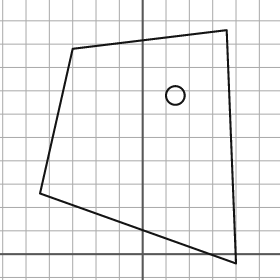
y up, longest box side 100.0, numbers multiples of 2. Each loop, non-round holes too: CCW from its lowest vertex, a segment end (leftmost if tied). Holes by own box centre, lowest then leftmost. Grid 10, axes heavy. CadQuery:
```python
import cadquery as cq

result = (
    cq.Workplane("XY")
    .moveTo(40.0, -4.0)
    .lineTo(36.0, 96.0)
    .lineTo(-30.0, 88.0)
    .lineTo(-44.0, 26.0)
    .close()
    .moveTo(14.0, 68.0)
    .circle(4.0)
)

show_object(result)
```